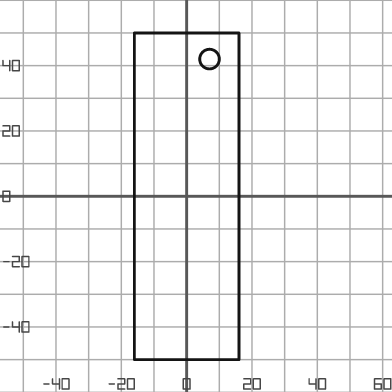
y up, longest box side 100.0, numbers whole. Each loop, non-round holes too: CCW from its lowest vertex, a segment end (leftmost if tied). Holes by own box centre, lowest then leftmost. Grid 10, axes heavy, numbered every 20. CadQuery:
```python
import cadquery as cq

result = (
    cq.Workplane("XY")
    .moveTo(-16.0, -50.0)
    .lineTo(16.0, -50.0)
    .lineTo(16.0, 50.0)
    .lineTo(-16.0, 50.0)
    .close()
    .moveTo(7.0, 42.0)
    .circle(3.0)
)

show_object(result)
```